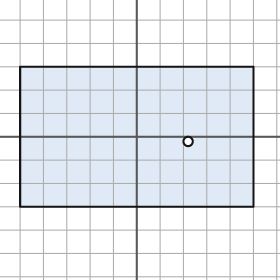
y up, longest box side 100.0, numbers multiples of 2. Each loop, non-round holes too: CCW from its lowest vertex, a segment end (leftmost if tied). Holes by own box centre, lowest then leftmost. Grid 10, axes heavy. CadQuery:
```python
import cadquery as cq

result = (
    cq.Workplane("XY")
    .moveTo(-50.0, -30.0)
    .lineTo(50.0, -30.0)
    .lineTo(50.0, 30.0)
    .lineTo(-50.0, 30.0)
    .close()
    .moveTo(22.0, -2.0)
    .circle(2.0)
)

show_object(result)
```